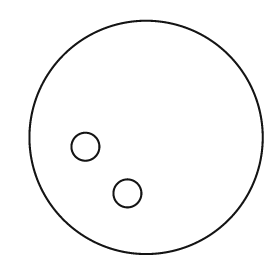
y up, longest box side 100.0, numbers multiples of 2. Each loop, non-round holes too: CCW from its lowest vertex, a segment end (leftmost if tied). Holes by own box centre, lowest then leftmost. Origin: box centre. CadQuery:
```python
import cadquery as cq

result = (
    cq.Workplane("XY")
    .moveTo(0.0, 0.0)
    .circle(50.0)
    .moveTo(-8.0, -24.0)
    .circle(6.0)
    .moveTo(-26.0, -4.0)
    .circle(6.0)
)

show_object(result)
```